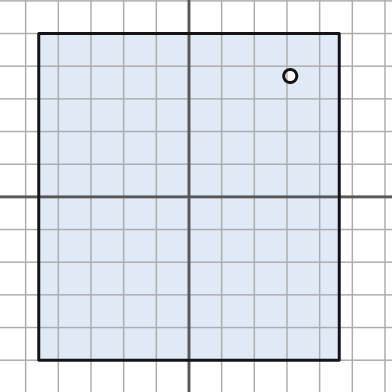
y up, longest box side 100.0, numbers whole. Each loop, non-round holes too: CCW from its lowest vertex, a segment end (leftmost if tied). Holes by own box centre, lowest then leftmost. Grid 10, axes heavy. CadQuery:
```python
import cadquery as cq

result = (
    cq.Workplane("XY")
    .moveTo(-46.0, -50.0)
    .lineTo(46.0, -50.0)
    .lineTo(46.0, 50.0)
    .lineTo(-46.0, 50.0)
    .close()
    .moveTo(31.0, 37.0)
    .circle(2.0)
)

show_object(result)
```